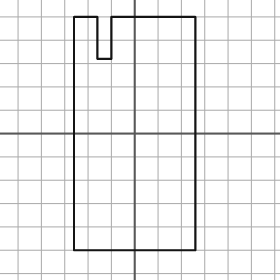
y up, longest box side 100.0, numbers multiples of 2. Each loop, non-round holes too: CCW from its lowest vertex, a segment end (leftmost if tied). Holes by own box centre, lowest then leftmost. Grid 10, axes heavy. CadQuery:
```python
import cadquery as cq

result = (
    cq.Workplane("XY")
    .moveTo(-26.0, -50.0)
    .lineTo(26.0, -50.0)
    .lineTo(26.0, 50.0)
    .lineTo(-10.0, 50.0)
    .lineTo(-10.0, 32.0)
    .lineTo(-16.0, 32.0)
    .lineTo(-16.0, 50.0)
    .lineTo(-26.0, 50.0)
    .close()
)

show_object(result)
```